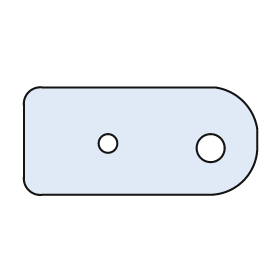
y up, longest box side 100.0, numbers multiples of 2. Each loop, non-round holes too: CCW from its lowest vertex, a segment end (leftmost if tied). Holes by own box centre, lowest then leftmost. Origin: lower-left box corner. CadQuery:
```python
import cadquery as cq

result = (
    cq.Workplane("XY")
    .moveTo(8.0, 0.0)
    .lineTo(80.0, 0.0)
    .threePointArc((94.0, 6.0), (100.0, 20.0))
    .lineTo(100.0, 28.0)
    .threePointArc((94.0, 40.0), (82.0, 46.0))
    .lineTo(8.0, 46.0)
    .threePointArc((2.0, 44.0), (0.0, 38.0))
    .lineTo(0.0, 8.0)
    .threePointArc((2.0, 2.0), (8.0, 0.0))
    .close()
    .moveTo(80.0, 20.0)
    .circle(6.0)
    .moveTo(36.0, 22.0)
    .circle(4.0)
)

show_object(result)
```